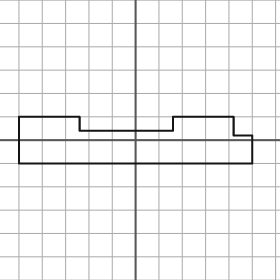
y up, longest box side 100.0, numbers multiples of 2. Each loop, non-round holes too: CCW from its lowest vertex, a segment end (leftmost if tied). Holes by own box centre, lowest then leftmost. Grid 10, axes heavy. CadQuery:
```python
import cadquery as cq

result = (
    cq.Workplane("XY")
    .moveTo(-50.0, -10.0)
    .lineTo(50.0, -10.0)
    .lineTo(50.0, 2.0)
    .lineTo(42.0, 2.0)
    .lineTo(42.0, 10.0)
    .lineTo(16.0, 10.0)
    .lineTo(16.0, 4.0)
    .lineTo(-24.0, 4.0)
    .lineTo(-24.0, 10.0)
    .lineTo(-50.0, 10.0)
    .close()
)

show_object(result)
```